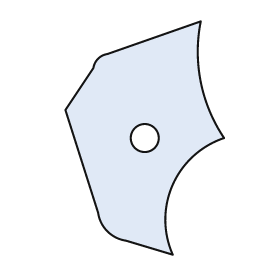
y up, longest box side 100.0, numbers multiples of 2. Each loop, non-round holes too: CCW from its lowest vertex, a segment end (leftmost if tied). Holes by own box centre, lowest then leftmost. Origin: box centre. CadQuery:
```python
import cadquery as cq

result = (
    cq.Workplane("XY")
    .moveTo(12.0, -50.0)
    .threePointArc((12.0, -20.0), (34.0, 0.0))
    .threePointArc((24.0, 24.0), (24.0, 50.0))
    .lineTo(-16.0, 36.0)
    .threePointArc((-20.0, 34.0), (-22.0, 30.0))
    .lineTo(-34.0, 12.0)
    .lineTo(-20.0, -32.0)
    .threePointArc((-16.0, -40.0), (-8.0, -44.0))
    .close()
    .moveTo(0.0, 0.0)
    .circle(6.0)
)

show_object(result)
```